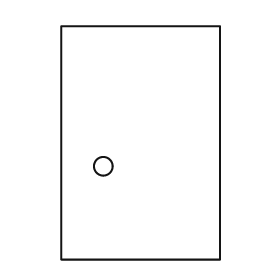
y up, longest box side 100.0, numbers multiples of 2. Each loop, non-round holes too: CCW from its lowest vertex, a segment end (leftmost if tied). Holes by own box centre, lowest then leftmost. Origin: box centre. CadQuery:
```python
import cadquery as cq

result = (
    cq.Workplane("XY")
    .moveTo(-34.0, -50.0)
    .lineTo(34.0, -50.0)
    .lineTo(34.0, 50.0)
    .lineTo(-34.0, 50.0)
    .close()
    .moveTo(-16.0, -10.0)
    .circle(4.0)
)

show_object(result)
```